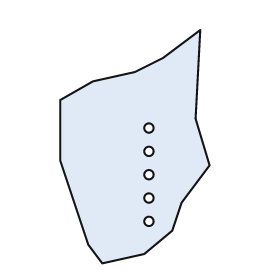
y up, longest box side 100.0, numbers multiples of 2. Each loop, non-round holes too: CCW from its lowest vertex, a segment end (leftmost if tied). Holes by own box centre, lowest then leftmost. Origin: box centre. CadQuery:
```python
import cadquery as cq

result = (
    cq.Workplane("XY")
    .moveTo(-14.0, -50.0)
    .lineTo(4.0, -46.0)
    .lineTo(16.0, -36.0)
    .lineTo(20.0, -24.0)
    .lineTo(32.0, -8.0)
    .lineTo(26.0, 12.0)
    .lineTo(28.0, 50.0)
    .lineTo(12.0, 38.0)
    .lineTo(0.0, 32.0)
    .lineTo(-18.0, 28.0)
    .lineTo(-32.0, 20.0)
    .lineTo(-32.0, -6.0)
    .lineTo(-20.0, -42.0)
    .close()
    .moveTo(6.0, -32.0)
    .circle(2.0)
    .moveTo(6.0, -22.0)
    .circle(2.0)
    .moveTo(6.0, -12.0)
    .circle(2.0)
    .moveTo(6.0, -2.0)
    .circle(2.0)
    .moveTo(6.0, 8.0)
    .circle(2.0)
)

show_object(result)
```